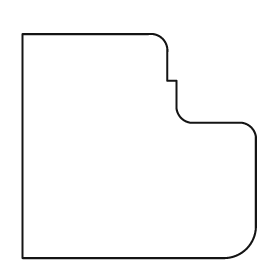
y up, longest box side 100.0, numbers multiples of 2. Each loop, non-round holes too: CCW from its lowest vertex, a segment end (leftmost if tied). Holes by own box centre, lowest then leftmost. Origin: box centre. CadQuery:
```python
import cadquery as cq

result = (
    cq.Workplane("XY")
    .moveTo(-50.0, -48.0)
    .lineTo(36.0, -48.0)
    .threePointArc((46.0, -44.0), (50.0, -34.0))
    .lineTo(50.0, 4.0)
    .threePointArc((48.0, 8.0), (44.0, 10.0))
    .lineTo(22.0, 10.0)
    .threePointArc((18.0, 12.0), (16.0, 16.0))
    .lineTo(16.0, 28.0)
    .lineTo(12.0, 28.0)
    .lineTo(12.0, 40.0)
    .threePointArc((10.0, 46.0), (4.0, 48.0))
    .lineTo(-50.0, 48.0)
    .close()
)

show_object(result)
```